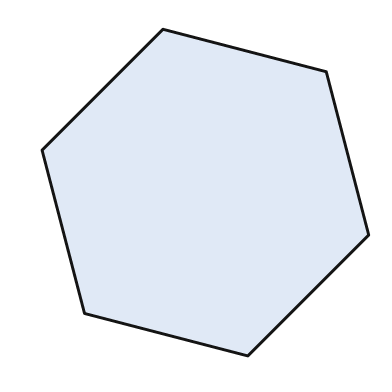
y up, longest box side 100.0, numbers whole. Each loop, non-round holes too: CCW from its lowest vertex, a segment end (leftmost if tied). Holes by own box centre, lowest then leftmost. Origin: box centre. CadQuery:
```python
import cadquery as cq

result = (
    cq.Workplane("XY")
    .moveTo(13.0, -50.0)
    .lineTo(50.0, -13.0)
    .lineTo(37.0, 37.0)
    .lineTo(-13.0, 50.0)
    .lineTo(-50.0, 13.0)
    .lineTo(-37.0, -37.0)
    .close()
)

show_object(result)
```